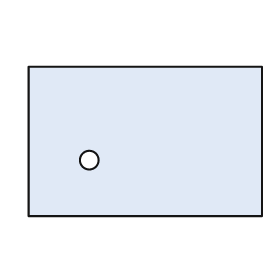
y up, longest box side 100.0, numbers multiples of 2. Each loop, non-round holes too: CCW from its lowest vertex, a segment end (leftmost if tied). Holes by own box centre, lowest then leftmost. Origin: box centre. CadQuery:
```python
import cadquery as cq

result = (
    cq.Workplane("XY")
    .moveTo(-50.0, -32.0)
    .lineTo(50.0, -32.0)
    .lineTo(50.0, 32.0)
    .lineTo(-50.0, 32.0)
    .close()
    .moveTo(-24.0, -8.0)
    .circle(4.0)
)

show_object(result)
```